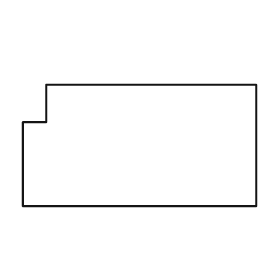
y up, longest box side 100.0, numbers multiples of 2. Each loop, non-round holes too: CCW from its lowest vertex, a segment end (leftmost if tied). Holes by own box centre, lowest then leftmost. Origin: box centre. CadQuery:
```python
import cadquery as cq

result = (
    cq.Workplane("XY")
    .moveTo(-50.0, -26.0)
    .lineTo(50.0, -26.0)
    .lineTo(50.0, 26.0)
    .lineTo(-40.0, 26.0)
    .lineTo(-40.0, 10.0)
    .lineTo(-50.0, 10.0)
    .close()
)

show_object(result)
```